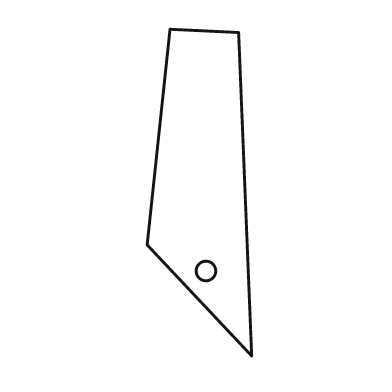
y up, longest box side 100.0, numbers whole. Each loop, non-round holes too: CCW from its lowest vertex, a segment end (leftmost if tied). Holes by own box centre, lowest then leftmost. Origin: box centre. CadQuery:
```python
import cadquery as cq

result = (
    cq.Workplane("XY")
    .moveTo(16.0, -50.0)
    .lineTo(12.0, 49.0)
    .lineTo(-9.0, 50.0)
    .lineTo(-16.0, -16.0)
    .close()
    .moveTo(2.0, -24.0)
    .circle(3.0)
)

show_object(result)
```